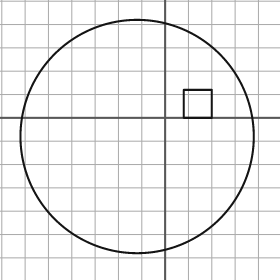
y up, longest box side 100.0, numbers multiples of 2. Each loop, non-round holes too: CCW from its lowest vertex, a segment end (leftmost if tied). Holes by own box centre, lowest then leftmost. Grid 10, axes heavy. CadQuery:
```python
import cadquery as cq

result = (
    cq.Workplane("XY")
    .moveTo(-12.0, -8.0)
    .circle(50.0)
    .moveTo(8.0, 0.0)
    .lineTo(20.0, 0.0)
    .lineTo(20.0, 12.0)
    .lineTo(8.0, 12.0)
    .close()
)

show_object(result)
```